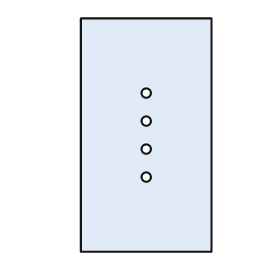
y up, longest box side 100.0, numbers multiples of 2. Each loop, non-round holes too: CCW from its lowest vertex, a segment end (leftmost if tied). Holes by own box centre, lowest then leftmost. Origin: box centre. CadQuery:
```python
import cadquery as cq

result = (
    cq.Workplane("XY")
    .moveTo(-28.0, -50.0)
    .lineTo(28.0, -50.0)
    .lineTo(28.0, 50.0)
    .lineTo(-28.0, 50.0)
    .close()
    .moveTo(0.0, -18.0)
    .circle(2.0)
    .moveTo(0.0, -6.0)
    .circle(2.0)
    .moveTo(0.0, 6.0)
    .circle(2.0)
    .moveTo(0.0, 18.0)
    .circle(2.0)
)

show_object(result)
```